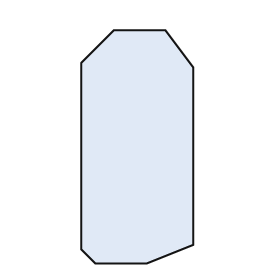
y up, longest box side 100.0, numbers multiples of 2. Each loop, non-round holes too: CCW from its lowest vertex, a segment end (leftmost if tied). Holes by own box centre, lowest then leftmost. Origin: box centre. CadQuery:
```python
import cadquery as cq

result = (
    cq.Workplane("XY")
    .moveTo(-18.0, -50.0)
    .lineTo(4.0, -50.0)
    .lineTo(24.0, -42.0)
    .lineTo(24.0, 34.0)
    .lineTo(12.0, 50.0)
    .lineTo(-10.0, 50.0)
    .lineTo(-24.0, 36.0)
    .lineTo(-24.0, -44.0)
    .close()
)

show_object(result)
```